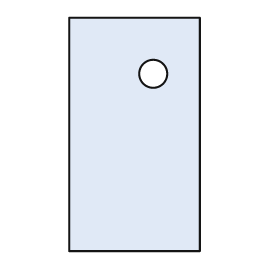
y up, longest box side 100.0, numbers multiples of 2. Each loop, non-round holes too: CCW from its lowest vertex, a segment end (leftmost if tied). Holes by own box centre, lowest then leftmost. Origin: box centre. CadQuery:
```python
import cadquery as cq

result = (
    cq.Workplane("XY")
    .moveTo(-28.0, -50.0)
    .lineTo(28.0, -50.0)
    .lineTo(28.0, 50.0)
    .lineTo(-28.0, 50.0)
    .close()
    .moveTo(8.0, 26.0)
    .circle(6.0)
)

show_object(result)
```